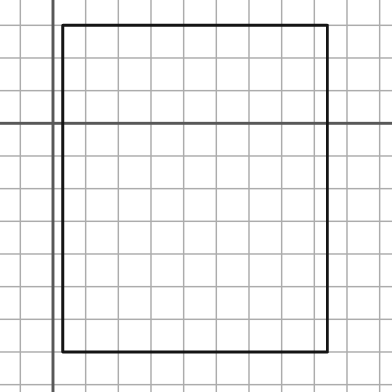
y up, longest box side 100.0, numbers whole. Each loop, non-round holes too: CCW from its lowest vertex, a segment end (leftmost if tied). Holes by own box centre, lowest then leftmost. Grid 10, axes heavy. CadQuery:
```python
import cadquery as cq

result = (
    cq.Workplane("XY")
    .moveTo(3.0, -70.0)
    .lineTo(84.0, -70.0)
    .lineTo(84.0, 30.0)
    .lineTo(3.0, 30.0)
    .close()
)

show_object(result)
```